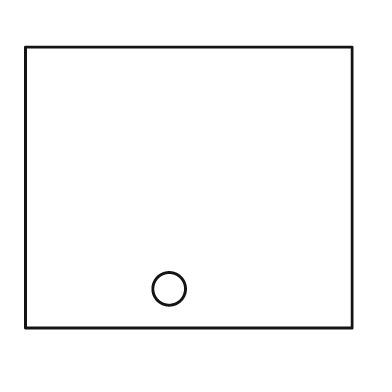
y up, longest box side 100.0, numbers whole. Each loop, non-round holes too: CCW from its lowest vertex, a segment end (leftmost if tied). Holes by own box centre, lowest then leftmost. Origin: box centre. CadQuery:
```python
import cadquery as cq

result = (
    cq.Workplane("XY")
    .moveTo(-50.0, -43.0)
    .lineTo(50.0, -43.0)
    .lineTo(50.0, 43.0)
    .lineTo(-50.0, 43.0)
    .close()
    .moveTo(-6.0, -31.0)
    .circle(5.0)
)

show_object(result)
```